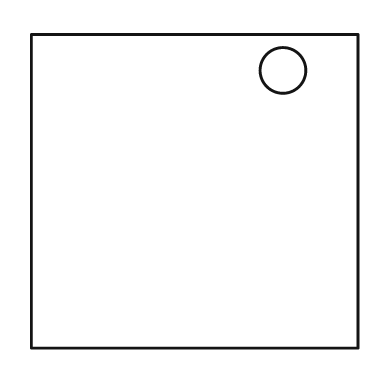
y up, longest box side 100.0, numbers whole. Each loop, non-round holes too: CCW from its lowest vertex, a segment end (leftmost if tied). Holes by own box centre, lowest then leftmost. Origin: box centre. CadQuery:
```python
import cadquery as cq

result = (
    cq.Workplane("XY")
    .moveTo(-50.0, -48.0)
    .lineTo(50.0, -48.0)
    .lineTo(50.0, 48.0)
    .lineTo(-50.0, 48.0)
    .close()
    .moveTo(27.0, 37.0)
    .circle(7.0)
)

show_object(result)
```